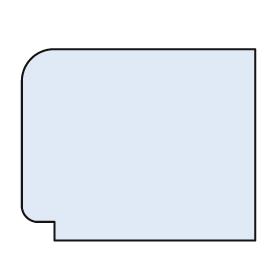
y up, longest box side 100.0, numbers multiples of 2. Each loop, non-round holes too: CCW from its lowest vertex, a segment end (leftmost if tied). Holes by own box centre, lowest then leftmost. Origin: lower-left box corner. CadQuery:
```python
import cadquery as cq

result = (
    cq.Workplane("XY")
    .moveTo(14.0, 0.0)
    .lineTo(100.0, 0.0)
    .lineTo(100.0, 82.0)
    .lineTo(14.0, 82.0)
    .threePointArc((4.0, 78.0), (0.0, 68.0))
    .lineTo(0.0, 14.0)
    .threePointArc((2.0, 10.0), (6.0, 8.0))
    .lineTo(14.0, 8.0)
    .close()
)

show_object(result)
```